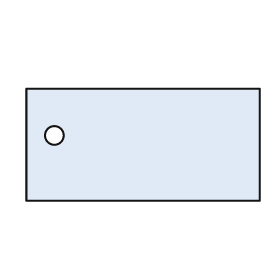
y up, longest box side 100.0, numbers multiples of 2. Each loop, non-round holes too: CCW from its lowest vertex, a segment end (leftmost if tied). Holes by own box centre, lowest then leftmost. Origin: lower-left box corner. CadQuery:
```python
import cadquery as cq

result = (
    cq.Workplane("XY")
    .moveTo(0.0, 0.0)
    .lineTo(100.0, 0.0)
    .lineTo(100.0, 48.0)
    .lineTo(0.0, 48.0)
    .close()
    .moveTo(12.0, 28.0)
    .circle(4.0)
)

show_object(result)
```